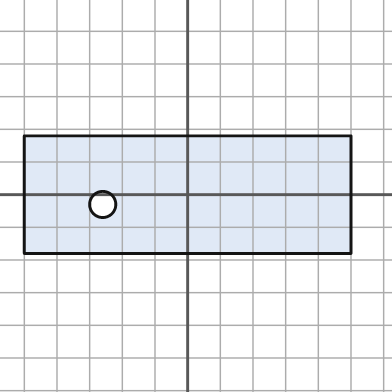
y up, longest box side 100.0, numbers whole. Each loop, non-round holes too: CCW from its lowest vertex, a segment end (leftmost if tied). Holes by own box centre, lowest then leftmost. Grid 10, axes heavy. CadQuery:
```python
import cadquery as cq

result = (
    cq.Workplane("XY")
    .moveTo(-50.0, -18.0)
    .lineTo(50.0, -18.0)
    .lineTo(50.0, 18.0)
    .lineTo(-50.0, 18.0)
    .close()
    .moveTo(-26.0, -3.0)
    .circle(4.0)
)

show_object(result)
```